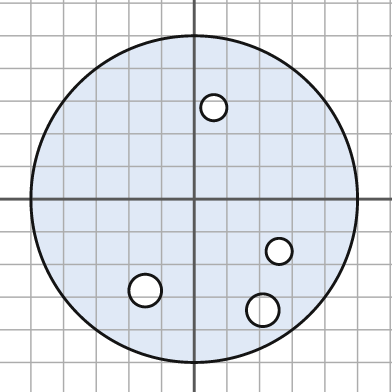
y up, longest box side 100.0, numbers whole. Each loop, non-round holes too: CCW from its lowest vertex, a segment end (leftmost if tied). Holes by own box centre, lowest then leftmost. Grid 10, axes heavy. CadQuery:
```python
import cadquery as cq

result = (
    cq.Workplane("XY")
    .moveTo(0.0, 0.0)
    .circle(50.0)
    .moveTo(21.0, -34.0)
    .circle(5.0)
    .moveTo(-15.0, -28.0)
    .circle(5.0)
    .moveTo(26.0, -16.0)
    .circle(4.0)
    .moveTo(6.0, 28.0)
    .circle(4.0)
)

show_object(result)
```